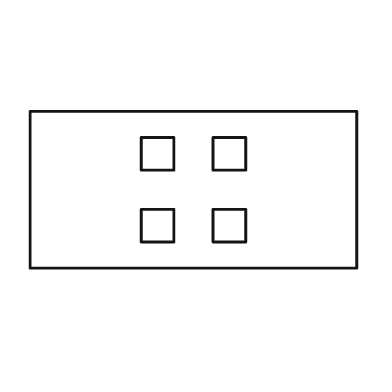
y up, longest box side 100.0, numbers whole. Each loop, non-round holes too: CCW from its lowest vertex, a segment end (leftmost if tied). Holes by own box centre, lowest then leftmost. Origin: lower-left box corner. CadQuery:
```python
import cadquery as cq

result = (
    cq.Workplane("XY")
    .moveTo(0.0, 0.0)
    .lineTo(100.0, 0.0)
    .lineTo(100.0, 48.0)
    .lineTo(0.0, 48.0)
    .close()
    .moveTo(34.0, 8.0)
    .lineTo(44.0, 8.0)
    .lineTo(44.0, 18.0)
    .lineTo(34.0, 18.0)
    .close()
    .moveTo(56.0, 8.0)
    .lineTo(66.0, 8.0)
    .lineTo(66.0, 18.0)
    .lineTo(56.0, 18.0)
    .close()
    .moveTo(34.0, 30.0)
    .lineTo(44.0, 30.0)
    .lineTo(44.0, 40.0)
    .lineTo(34.0, 40.0)
    .close()
    .moveTo(56.0, 30.0)
    .lineTo(66.0, 30.0)
    .lineTo(66.0, 40.0)
    .lineTo(56.0, 40.0)
    .close()
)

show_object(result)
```